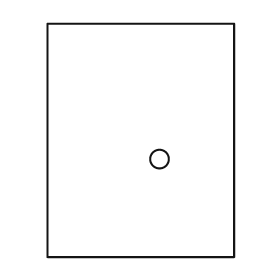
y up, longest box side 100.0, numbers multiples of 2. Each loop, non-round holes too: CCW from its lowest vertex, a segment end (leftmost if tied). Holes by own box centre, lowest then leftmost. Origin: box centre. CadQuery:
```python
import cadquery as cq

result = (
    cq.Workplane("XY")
    .moveTo(-40.0, -50.0)
    .lineTo(40.0, -50.0)
    .lineTo(40.0, 50.0)
    .lineTo(-40.0, 50.0)
    .close()
    .moveTo(8.0, -8.0)
    .circle(4.0)
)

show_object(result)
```